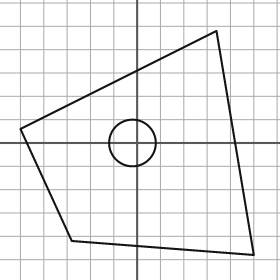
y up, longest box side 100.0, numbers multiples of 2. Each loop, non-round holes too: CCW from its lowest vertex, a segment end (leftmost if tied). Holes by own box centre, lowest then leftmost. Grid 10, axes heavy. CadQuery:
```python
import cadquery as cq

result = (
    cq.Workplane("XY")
    .moveTo(50.0, -48.0)
    .lineTo(34.0, 48.0)
    .lineTo(-50.0, 6.0)
    .lineTo(-28.0, -42.0)
    .close()
    .moveTo(-2.0, 0.0)
    .circle(10.0)
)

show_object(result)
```